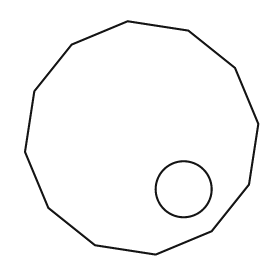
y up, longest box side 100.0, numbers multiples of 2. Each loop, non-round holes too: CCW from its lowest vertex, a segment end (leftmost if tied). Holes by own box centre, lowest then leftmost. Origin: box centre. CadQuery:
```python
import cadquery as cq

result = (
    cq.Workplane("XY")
    .moveTo(6.0, -50.0)
    .lineTo(30.0, -40.0)
    .lineTo(46.0, -20.0)
    .lineTo(50.0, 6.0)
    .lineTo(40.0, 30.0)
    .lineTo(20.0, 46.0)
    .lineTo(-6.0, 50.0)
    .lineTo(-30.0, 40.0)
    .lineTo(-46.0, 20.0)
    .lineTo(-50.0, -6.0)
    .lineTo(-40.0, -30.0)
    .lineTo(-20.0, -46.0)
    .close()
    .moveTo(18.0, -22.0)
    .circle(12.0)
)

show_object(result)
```